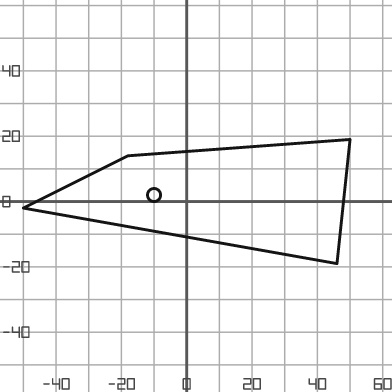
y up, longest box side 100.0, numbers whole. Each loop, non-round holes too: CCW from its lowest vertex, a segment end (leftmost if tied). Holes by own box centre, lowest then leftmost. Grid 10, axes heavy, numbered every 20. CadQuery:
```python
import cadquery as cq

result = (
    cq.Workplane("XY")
    .moveTo(46.0, -19.0)
    .lineTo(50.0, 19.0)
    .lineTo(-18.0, 14.0)
    .lineTo(-50.0, -2.0)
    .close()
    .moveTo(-10.0, 2.0)
    .circle(2.0)
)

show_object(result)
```